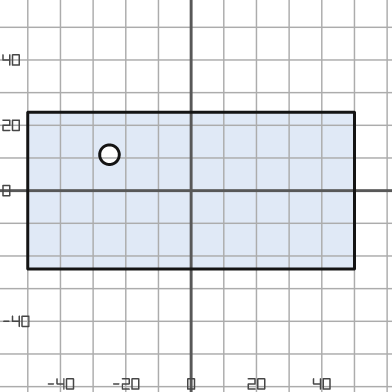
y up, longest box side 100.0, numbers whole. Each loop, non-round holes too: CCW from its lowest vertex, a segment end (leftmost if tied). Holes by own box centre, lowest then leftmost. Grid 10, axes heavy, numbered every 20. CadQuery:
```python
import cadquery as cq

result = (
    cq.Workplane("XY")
    .moveTo(-50.0, -24.0)
    .lineTo(50.0, -24.0)
    .lineTo(50.0, 24.0)
    .lineTo(-50.0, 24.0)
    .close()
    .moveTo(-25.0, 11.0)
    .circle(3.0)
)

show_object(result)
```